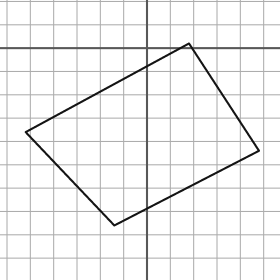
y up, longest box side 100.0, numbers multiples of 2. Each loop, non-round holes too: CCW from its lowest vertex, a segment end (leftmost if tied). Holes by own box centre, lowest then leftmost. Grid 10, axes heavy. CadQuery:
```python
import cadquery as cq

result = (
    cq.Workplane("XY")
    .moveTo(-14.0, -76.0)
    .lineTo(48.0, -44.0)
    .lineTo(18.0, 2.0)
    .lineTo(-52.0, -36.0)
    .close()
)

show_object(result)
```